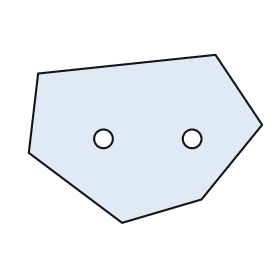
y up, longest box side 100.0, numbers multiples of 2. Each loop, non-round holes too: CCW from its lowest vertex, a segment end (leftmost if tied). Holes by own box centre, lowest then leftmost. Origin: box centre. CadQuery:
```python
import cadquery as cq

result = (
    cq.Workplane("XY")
    .moveTo(-10.0, -36.0)
    .lineTo(24.0, -26.0)
    .lineTo(50.0, 6.0)
    .lineTo(30.0, 36.0)
    .lineTo(-46.0, 28.0)
    .lineTo(-50.0, -6.0)
    .close()
    .moveTo(-18.0, 0.0)
    .circle(4.0)
    .moveTo(20.0, 0.0)
    .circle(4.0)
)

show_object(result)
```